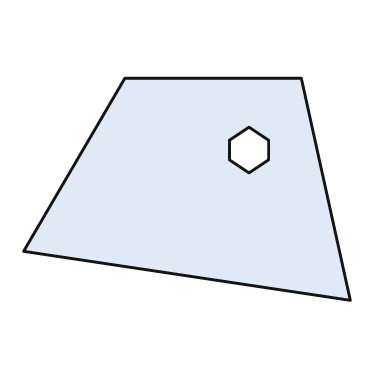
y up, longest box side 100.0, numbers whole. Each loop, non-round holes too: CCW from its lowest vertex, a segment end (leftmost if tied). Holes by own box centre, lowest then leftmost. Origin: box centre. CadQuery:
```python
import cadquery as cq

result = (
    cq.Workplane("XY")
    .moveTo(50.0, -34.0)
    .lineTo(35.0, 34.0)
    .lineTo(-19.0, 34.0)
    .lineTo(-50.0, -19.0)
    .close()
    .moveTo(19.0, 5.0)
    .lineTo(25.0, 9.0)
    .lineTo(25.0, 15.0)
    .lineTo(19.0, 19.0)
    .lineTo(13.0, 15.0)
    .lineTo(13.0, 9.0)
    .close()
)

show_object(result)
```